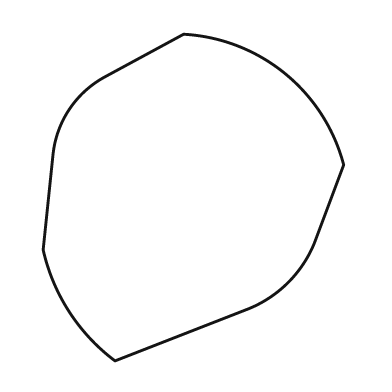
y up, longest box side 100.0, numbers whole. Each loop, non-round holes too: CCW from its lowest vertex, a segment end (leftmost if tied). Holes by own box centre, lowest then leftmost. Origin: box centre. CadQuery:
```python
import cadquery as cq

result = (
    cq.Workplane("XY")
    .moveTo(-24.0, -50.0)
    .lineTo(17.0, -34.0)
    .threePointArc((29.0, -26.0), (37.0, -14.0))
    .lineTo(46.0, 10.0)
    .threePointArc((28.0, 38.0), (-3.0, 50.0))
    .lineTo(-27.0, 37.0)
    .threePointArc((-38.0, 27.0), (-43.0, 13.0))
    .lineTo(-46.0, -16.0)
    .threePointArc((-38.0, -35.0), (-24.0, -50.0))
    .close()
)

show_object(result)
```